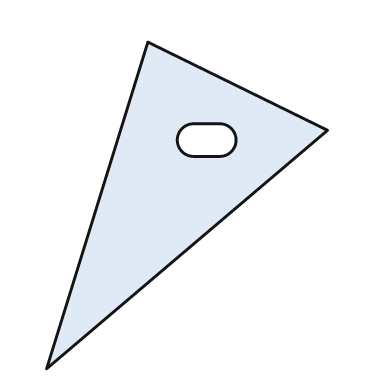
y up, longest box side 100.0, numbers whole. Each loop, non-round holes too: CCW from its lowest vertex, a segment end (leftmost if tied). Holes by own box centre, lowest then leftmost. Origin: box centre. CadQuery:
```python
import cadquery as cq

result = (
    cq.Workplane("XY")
    .moveTo(-43.0, -50.0)
    .lineTo(43.0, 23.0)
    .lineTo(-12.0, 50.0)
    .close()
    .moveTo(2.0, 15.0)
    .lineTo(10.0, 15.0)
    .threePointArc((15.0, 20.0), (10.0, 25.0))
    .lineTo(2.0, 25.0)
    .threePointArc((-3.0, 20.0), (2.0, 15.0))
    .close()
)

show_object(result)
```